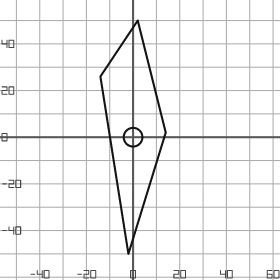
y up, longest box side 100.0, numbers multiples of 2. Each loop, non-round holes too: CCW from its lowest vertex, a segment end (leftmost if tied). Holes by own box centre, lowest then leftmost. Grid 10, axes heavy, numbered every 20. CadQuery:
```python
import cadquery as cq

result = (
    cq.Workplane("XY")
    .moveTo(-2.0, -50.0)
    .lineTo(14.0, 2.0)
    .lineTo(2.0, 50.0)
    .lineTo(-14.0, 26.0)
    .close()
    .moveTo(0.0, 0.0)
    .circle(4.0)
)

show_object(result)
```